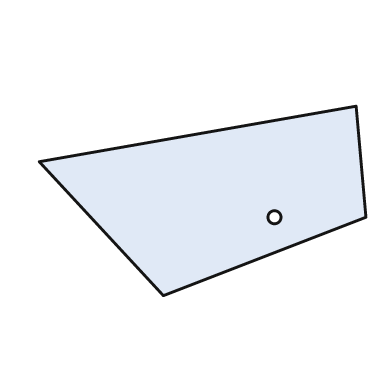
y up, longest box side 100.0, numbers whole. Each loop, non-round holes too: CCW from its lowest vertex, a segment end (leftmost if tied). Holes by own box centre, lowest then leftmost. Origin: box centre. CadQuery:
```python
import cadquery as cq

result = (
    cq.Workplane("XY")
    .moveTo(-12.0, -29.0)
    .lineTo(50.0, -5.0)
    .lineTo(47.0, 29.0)
    .lineTo(-50.0, 12.0)
    .close()
    .moveTo(22.0, -5.0)
    .circle(2.0)
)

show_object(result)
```